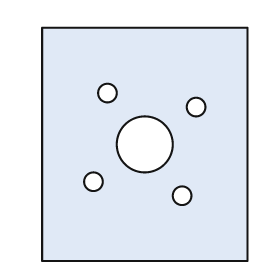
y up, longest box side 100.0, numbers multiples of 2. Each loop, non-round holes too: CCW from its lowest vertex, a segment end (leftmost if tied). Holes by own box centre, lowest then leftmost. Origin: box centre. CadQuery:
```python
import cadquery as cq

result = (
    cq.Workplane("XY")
    .moveTo(-44.0, -50.0)
    .lineTo(44.0, -50.0)
    .lineTo(44.0, 50.0)
    .lineTo(-44.0, 50.0)
    .close()
    .moveTo(16.0, -22.0)
    .circle(4.0)
    .moveTo(-22.0, -16.0)
    .circle(4.0)
    .moveTo(0.0, 0.0)
    .circle(12.0)
    .moveTo(22.0, 16.0)
    .circle(4.0)
    .moveTo(-16.0, 22.0)
    .circle(4.0)
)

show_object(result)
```